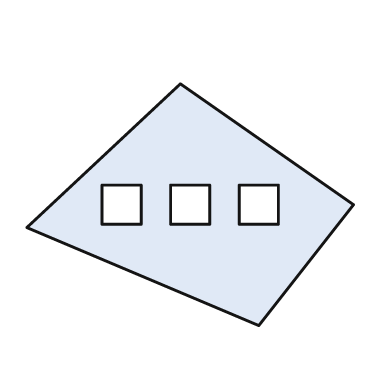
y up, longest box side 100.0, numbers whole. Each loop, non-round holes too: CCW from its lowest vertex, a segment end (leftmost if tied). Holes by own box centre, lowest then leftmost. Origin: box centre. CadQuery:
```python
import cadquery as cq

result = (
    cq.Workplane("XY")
    .moveTo(21.0, -37.0)
    .lineTo(50.0, 0.0)
    .lineTo(-3.0, 37.0)
    .lineTo(-50.0, -7.0)
    .close()
    .moveTo(-27.0, -6.0)
    .lineTo(-15.0, -6.0)
    .lineTo(-15.0, 6.0)
    .lineTo(-27.0, 6.0)
    .close()
    .moveTo(-6.0, -6.0)
    .lineTo(6.0, -6.0)
    .lineTo(6.0, 6.0)
    .lineTo(-6.0, 6.0)
    .close()
    .moveTo(15.0, -6.0)
    .lineTo(27.0, -6.0)
    .lineTo(27.0, 6.0)
    .lineTo(15.0, 6.0)
    .close()
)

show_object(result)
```